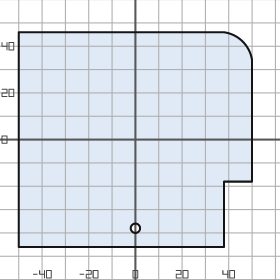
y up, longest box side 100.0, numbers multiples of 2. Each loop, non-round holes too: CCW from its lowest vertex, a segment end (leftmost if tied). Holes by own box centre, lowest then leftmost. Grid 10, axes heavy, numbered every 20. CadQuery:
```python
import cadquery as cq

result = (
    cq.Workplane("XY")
    .moveTo(-50.0, -46.0)
    .lineTo(38.0, -46.0)
    .lineTo(38.0, -18.0)
    .lineTo(50.0, -18.0)
    .lineTo(50.0, 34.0)
    .threePointArc((46.0, 42.0), (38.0, 46.0))
    .lineTo(-50.0, 46.0)
    .close()
    .moveTo(0.0, -38.0)
    .circle(2.0)
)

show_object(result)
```